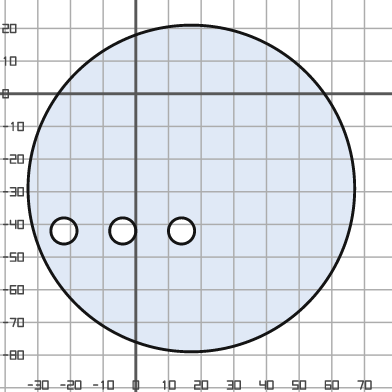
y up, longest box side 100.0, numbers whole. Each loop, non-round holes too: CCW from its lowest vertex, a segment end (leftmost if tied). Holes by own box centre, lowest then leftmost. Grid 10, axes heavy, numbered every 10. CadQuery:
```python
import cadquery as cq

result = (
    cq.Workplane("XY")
    .moveTo(17.0, -29.0)
    .circle(50.0)
    .moveTo(-22.0, -42.0)
    .circle(4.0)
    .moveTo(-4.0, -42.0)
    .circle(4.0)
    .moveTo(14.0, -42.0)
    .circle(4.0)
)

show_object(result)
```